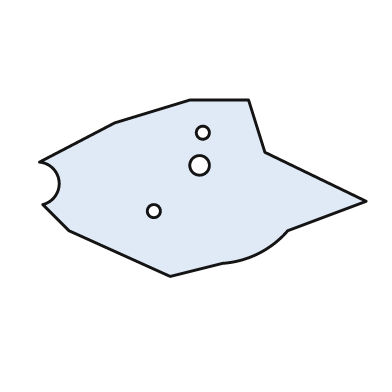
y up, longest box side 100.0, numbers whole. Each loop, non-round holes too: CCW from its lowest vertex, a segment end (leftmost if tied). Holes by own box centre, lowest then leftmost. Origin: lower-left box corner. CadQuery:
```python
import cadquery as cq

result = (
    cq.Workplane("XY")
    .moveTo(40.0, 0.0)
    .lineTo(56.0, 4.0)
    .threePointArc((67.0, 7.0), (76.0, 14.0))
    .lineTo(100.0, 23.0)
    .lineTo(69.0, 38.0)
    .lineTo(64.0, 54.0)
    .lineTo(46.0, 54.0)
    .lineTo(23.0, 47.0)
    .lineTo(0.0, 35.0)
    .threePointArc((6.0, 29.0), (1.0, 22.0))
    .lineTo(9.0, 14.0)
    .close()
    .moveTo(35.0, 20.0)
    .circle(2.0)
    .moveTo(49.0, 34.0)
    .circle(3.0)
    .moveTo(50.0, 44.0)
    .circle(2.0)
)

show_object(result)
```